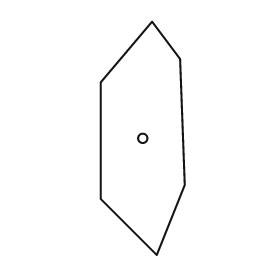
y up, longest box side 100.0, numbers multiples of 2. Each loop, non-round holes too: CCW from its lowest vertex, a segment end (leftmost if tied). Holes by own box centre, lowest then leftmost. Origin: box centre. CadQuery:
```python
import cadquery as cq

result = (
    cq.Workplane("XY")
    .moveTo(6.0, -50.0)
    .lineTo(18.0, -20.0)
    .lineTo(16.0, 34.0)
    .lineTo(4.0, 50.0)
    .lineTo(-18.0, 24.0)
    .lineTo(-18.0, -26.0)
    .close()
    .moveTo(0.0, 0.0)
    .circle(2.0)
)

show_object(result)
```